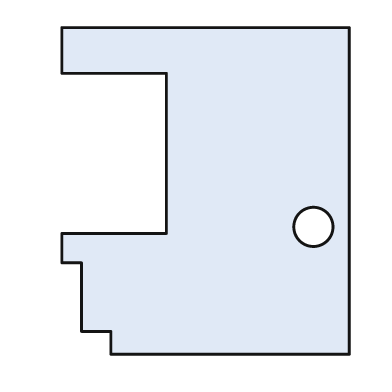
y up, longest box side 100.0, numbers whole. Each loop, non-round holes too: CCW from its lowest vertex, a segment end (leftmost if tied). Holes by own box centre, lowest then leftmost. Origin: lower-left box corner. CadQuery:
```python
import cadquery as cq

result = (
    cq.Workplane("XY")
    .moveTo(15.0, 0.0)
    .lineTo(88.0, 0.0)
    .lineTo(88.0, 100.0)
    .lineTo(0.0, 100.0)
    .lineTo(0.0, 86.0)
    .lineTo(32.0, 86.0)
    .lineTo(32.0, 37.0)
    .lineTo(0.0, 37.0)
    .lineTo(0.0, 28.0)
    .lineTo(6.0, 28.0)
    .lineTo(6.0, 7.0)
    .lineTo(15.0, 7.0)
    .close()
    .moveTo(77.0, 39.0)
    .circle(6.0)
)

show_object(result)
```